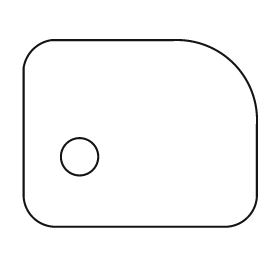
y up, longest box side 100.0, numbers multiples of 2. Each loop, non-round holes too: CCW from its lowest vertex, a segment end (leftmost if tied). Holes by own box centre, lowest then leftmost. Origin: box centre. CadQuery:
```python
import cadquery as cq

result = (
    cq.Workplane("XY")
    .moveTo(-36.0, -40.0)
    .lineTo(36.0, -40.0)
    .threePointArc((46.0, -36.0), (50.0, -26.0))
    .lineTo(50.0, 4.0)
    .threePointArc((40.0, 30.0), (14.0, 40.0))
    .lineTo(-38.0, 40.0)
    .threePointArc((-46.0, 36.0), (-50.0, 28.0))
    .lineTo(-50.0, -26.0)
    .threePointArc((-46.0, -36.0), (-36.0, -40.0))
    .close()
    .moveTo(-26.0, -10.0)
    .circle(8.0)
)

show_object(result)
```